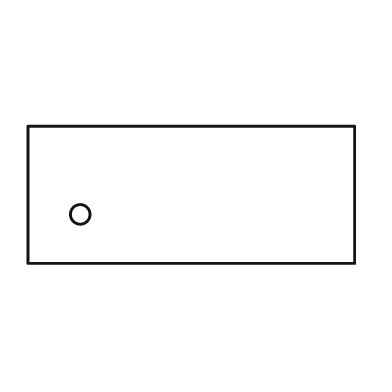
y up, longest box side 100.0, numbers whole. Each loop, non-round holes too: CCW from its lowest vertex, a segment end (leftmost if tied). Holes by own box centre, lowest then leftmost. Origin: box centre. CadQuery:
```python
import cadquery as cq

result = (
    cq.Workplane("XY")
    .moveTo(-50.0, -21.0)
    .lineTo(50.0, -21.0)
    .lineTo(50.0, 21.0)
    .lineTo(-50.0, 21.0)
    .close()
    .moveTo(-34.0, -6.0)
    .circle(3.0)
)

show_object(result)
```